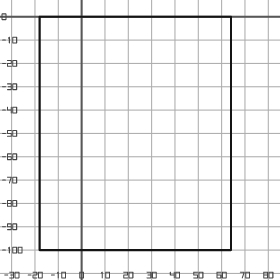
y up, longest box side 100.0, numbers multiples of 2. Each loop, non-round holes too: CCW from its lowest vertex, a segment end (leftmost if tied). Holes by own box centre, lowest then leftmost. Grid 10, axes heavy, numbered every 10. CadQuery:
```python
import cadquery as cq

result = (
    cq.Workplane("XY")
    .moveTo(-18.0, -100.0)
    .lineTo(64.0, -100.0)
    .lineTo(64.0, 0.0)
    .lineTo(-18.0, 0.0)
    .close()
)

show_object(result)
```